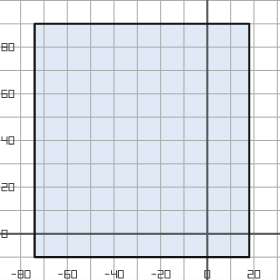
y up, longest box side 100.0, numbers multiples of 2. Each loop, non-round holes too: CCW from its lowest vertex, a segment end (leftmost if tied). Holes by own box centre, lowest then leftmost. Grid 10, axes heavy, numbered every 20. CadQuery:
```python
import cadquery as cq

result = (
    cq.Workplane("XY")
    .moveTo(-74.0, -10.0)
    .lineTo(18.0, -10.0)
    .lineTo(18.0, 90.0)
    .lineTo(-74.0, 90.0)
    .close()
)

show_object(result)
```